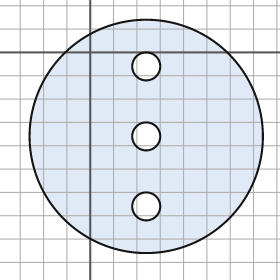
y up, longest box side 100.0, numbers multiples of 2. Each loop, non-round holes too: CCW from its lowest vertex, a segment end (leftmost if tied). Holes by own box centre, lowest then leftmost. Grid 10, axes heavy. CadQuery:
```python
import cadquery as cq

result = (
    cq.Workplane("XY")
    .moveTo(24.0, -36.0)
    .circle(50.0)
    .moveTo(24.0, -66.0)
    .circle(6.0)
    .moveTo(24.0, -36.0)
    .circle(6.0)
    .moveTo(24.0, -6.0)
    .circle(6.0)
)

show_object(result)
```